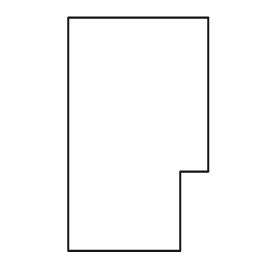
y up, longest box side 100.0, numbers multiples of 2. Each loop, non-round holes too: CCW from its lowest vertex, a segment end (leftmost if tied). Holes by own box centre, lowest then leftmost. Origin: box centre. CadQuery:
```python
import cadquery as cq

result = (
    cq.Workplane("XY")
    .moveTo(-30.0, -50.0)
    .lineTo(18.0, -50.0)
    .lineTo(18.0, -16.0)
    .lineTo(30.0, -16.0)
    .lineTo(30.0, 50.0)
    .lineTo(-30.0, 50.0)
    .close()
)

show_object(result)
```